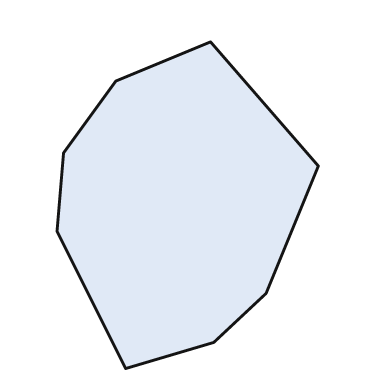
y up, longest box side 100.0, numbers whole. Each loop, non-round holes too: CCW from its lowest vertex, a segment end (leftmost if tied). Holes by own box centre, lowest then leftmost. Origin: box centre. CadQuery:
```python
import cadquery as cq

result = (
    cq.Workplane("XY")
    .moveTo(-19.0, -50.0)
    .lineTo(8.0, -42.0)
    .lineTo(24.0, -27.0)
    .lineTo(40.0, 12.0)
    .lineTo(7.0, 50.0)
    .lineTo(-22.0, 38.0)
    .lineTo(-38.0, 16.0)
    .lineTo(-40.0, -8.0)
    .close()
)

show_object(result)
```